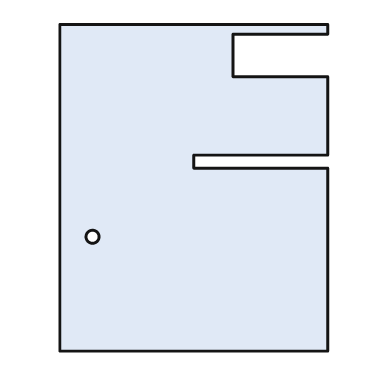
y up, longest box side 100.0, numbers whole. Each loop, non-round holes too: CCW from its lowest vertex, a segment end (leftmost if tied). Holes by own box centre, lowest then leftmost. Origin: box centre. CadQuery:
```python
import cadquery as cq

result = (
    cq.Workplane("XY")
    .moveTo(-41.0, -50.0)
    .lineTo(41.0, -50.0)
    .lineTo(41.0, 6.0)
    .lineTo(0.0, 6.0)
    .lineTo(0.0, 10.0)
    .lineTo(41.0, 10.0)
    .lineTo(41.0, 34.0)
    .lineTo(12.0, 34.0)
    .lineTo(12.0, 47.0)
    .lineTo(41.0, 47.0)
    .lineTo(41.0, 50.0)
    .lineTo(-41.0, 50.0)
    .close()
    .moveTo(-31.0, -15.0)
    .circle(2.0)
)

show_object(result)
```